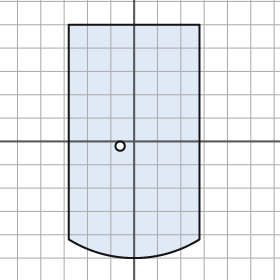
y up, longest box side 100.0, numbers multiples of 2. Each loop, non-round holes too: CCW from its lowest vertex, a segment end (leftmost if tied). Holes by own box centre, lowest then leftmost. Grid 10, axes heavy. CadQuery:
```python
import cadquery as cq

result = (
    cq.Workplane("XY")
    .moveTo(-28.0, -42.0)
    .threePointArc((0.0, -50.0), (28.0, -42.0))
    .lineTo(28.0, 50.0)
    .lineTo(-28.0, 50.0)
    .close()
    .moveTo(-6.0, -2.0)
    .circle(2.0)
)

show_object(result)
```